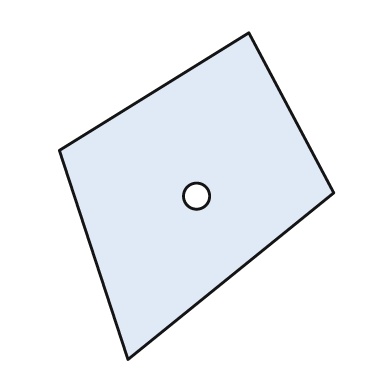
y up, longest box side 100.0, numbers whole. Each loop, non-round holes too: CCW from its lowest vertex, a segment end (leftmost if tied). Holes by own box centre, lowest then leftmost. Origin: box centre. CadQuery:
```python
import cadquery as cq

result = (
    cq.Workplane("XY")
    .moveTo(-21.0, -50.0)
    .lineTo(42.0, 1.0)
    .lineTo(16.0, 50.0)
    .lineTo(-42.0, 14.0)
    .close()
    .moveTo(0.0, 0.0)
    .circle(4.0)
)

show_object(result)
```